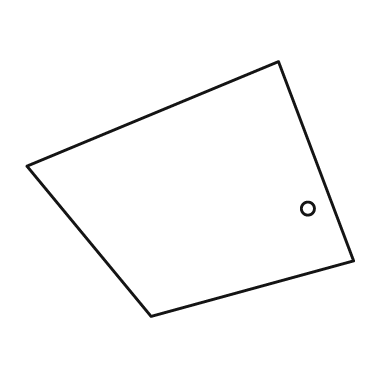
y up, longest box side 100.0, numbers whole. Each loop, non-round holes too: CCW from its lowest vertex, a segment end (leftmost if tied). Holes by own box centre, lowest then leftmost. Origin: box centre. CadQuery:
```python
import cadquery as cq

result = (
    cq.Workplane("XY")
    .moveTo(-12.0, -39.0)
    .lineTo(50.0, -22.0)
    .lineTo(27.0, 39.0)
    .lineTo(-50.0, 7.0)
    .close()
    .moveTo(36.0, -6.0)
    .circle(2.0)
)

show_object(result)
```